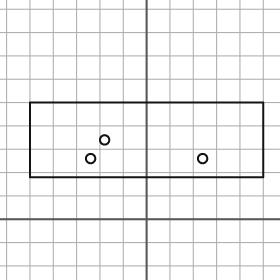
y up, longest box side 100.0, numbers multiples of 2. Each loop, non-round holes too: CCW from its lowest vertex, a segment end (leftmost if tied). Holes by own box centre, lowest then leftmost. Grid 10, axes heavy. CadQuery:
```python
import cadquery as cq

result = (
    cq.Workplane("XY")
    .moveTo(-50.0, 18.0)
    .lineTo(50.0, 18.0)
    .lineTo(50.0, 50.0)
    .lineTo(-50.0, 50.0)
    .close()
    .moveTo(-24.0, 26.0)
    .circle(2.0)
    .moveTo(24.0, 26.0)
    .circle(2.0)
    .moveTo(-18.0, 34.0)
    .circle(2.0)
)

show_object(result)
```